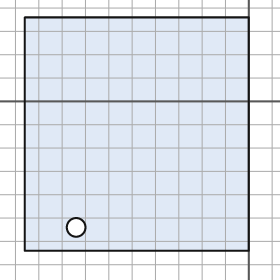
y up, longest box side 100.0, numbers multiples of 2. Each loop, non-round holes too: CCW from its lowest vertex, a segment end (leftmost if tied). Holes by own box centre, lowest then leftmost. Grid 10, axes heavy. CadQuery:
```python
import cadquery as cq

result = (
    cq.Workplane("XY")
    .moveTo(-96.0, -64.0)
    .lineTo(0.0, -64.0)
    .lineTo(0.0, 36.0)
    .lineTo(-96.0, 36.0)
    .close()
    .moveTo(-74.0, -54.0)
    .circle(4.0)
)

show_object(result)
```